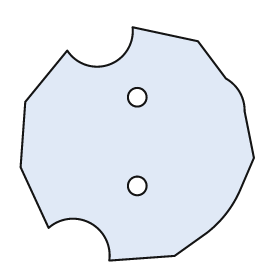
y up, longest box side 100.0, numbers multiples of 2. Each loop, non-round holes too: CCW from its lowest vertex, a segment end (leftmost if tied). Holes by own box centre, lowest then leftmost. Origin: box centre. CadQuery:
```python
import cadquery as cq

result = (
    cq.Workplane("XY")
    .moveTo(-12.0, -50.0)
    .lineTo(16.0, -48.0)
    .lineTo(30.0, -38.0)
    .threePointArc((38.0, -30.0), (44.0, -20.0))
    .lineTo(50.0, -6.0)
    .lineTo(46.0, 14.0)
    .threePointArc((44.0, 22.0), (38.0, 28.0))
    .lineTo(26.0, 44.0)
    .lineTo(-2.0, 50.0)
    .threePointArc((-12.0, 34.0), (-30.0, 40.0))
    .lineTo(-48.0, 18.0)
    .lineTo(-50.0, -10.0)
    .lineTo(-38.0, -36.0)
    .threePointArc((-20.0, -34.0), (-12.0, -50.0))
    .close()
    .moveTo(0.0, -18.0)
    .circle(4.0)
    .moveTo(0.0, 20.0)
    .circle(4.0)
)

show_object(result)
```